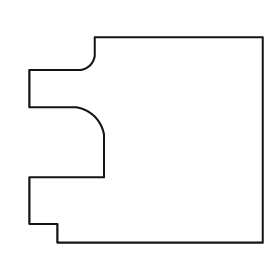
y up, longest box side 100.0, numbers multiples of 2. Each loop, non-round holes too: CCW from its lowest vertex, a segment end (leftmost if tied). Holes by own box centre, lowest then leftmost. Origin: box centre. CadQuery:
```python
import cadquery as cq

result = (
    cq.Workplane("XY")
    .moveTo(-38.0, -44.0)
    .lineTo(50.0, -44.0)
    .lineTo(50.0, 44.0)
    .lineTo(-22.0, 44.0)
    .lineTo(-22.0, 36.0)
    .threePointArc((-24.0, 32.0), (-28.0, 30.0))
    .lineTo(-50.0, 30.0)
    .lineTo(-50.0, 14.0)
    .lineTo(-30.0, 14.0)
    .threePointArc((-22.0, 10.0), (-18.0, 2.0))
    .lineTo(-18.0, -16.0)
    .lineTo(-50.0, -16.0)
    .lineTo(-50.0, -36.0)
    .lineTo(-38.0, -36.0)
    .close()
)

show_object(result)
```